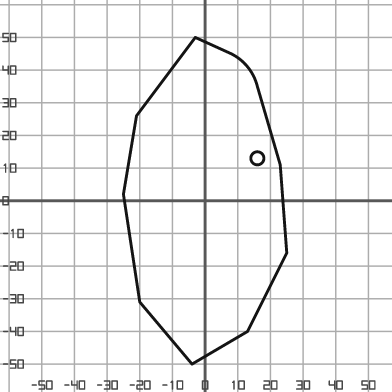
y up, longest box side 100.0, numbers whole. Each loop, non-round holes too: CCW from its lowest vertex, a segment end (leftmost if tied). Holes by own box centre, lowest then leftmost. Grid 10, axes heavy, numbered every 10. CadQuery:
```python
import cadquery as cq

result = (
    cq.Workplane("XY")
    .moveTo(-4.0, -50.0)
    .lineTo(13.0, -40.0)
    .lineTo(25.0, -16.0)
    .lineTo(23.0, 11.0)
    .lineTo(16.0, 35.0)
    .threePointArc((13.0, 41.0), (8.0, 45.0))
    .lineTo(-3.0, 50.0)
    .lineTo(-21.0, 26.0)
    .lineTo(-25.0, 2.0)
    .lineTo(-20.0, -31.0)
    .close()
    .moveTo(16.0, 13.0)
    .circle(2.0)
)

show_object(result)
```